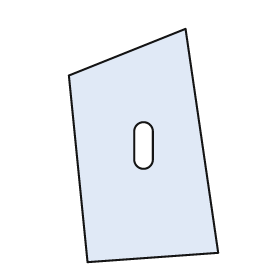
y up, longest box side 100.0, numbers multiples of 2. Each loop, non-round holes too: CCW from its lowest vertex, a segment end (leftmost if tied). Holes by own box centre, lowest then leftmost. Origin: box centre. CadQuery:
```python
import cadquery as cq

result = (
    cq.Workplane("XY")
    .moveTo(-24.0, -50.0)
    .lineTo(32.0, -46.0)
    .lineTo(18.0, 50.0)
    .lineTo(-32.0, 30.0)
    .close()
    .moveTo(-4.0, -6.0)
    .threePointArc((0.0, -10.0), (4.0, -6.0))
    .lineTo(4.0, 6.0)
    .threePointArc((0.0, 10.0), (-4.0, 6.0))
    .close()
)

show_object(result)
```